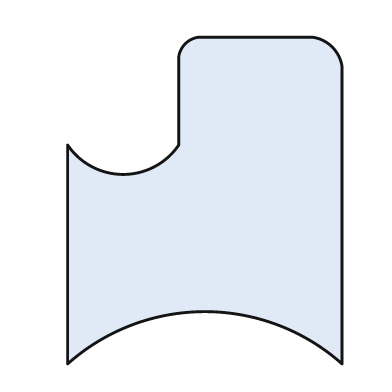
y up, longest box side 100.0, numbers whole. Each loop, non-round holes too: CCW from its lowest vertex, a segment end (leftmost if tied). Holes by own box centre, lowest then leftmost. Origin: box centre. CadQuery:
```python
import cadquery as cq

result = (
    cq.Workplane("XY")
    .moveTo(-42.0, -50.0)
    .threePointArc((0.0, -34.0), (42.0, -50.0))
    .lineTo(42.0, 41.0)
    .threePointArc((39.0, 47.0), (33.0, 50.0))
    .lineTo(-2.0, 50.0)
    .threePointArc((-6.0, 48.0), (-8.0, 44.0))
    .lineTo(-8.0, 17.0)
    .threePointArc((-25.0, 8.0), (-42.0, 17.0))
    .close()
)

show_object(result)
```